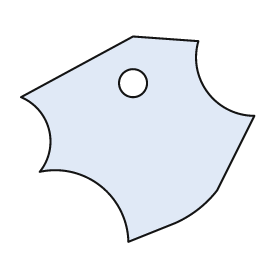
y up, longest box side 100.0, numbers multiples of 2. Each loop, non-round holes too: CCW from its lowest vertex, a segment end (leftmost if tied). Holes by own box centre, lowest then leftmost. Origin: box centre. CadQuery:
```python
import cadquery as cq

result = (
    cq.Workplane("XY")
    .moveTo(-4.0, -44.0)
    .lineTo(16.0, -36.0)
    .threePointArc((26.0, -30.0), (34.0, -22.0))
    .lineTo(50.0, 10.0)
    .threePointArc((30.0, 20.0), (26.0, 42.0))
    .lineTo(-2.0, 44.0)
    .lineTo(-50.0, 18.0)
    .threePointArc((-38.0, 4.0), (-42.0, -14.0))
    .threePointArc((-16.0, -20.0), (-4.0, -44.0))
    .close()
    .moveTo(-2.0, 24.0)
    .circle(6.0)
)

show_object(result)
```